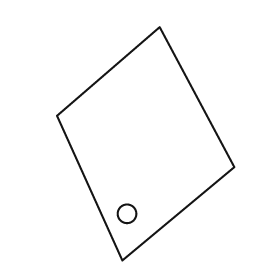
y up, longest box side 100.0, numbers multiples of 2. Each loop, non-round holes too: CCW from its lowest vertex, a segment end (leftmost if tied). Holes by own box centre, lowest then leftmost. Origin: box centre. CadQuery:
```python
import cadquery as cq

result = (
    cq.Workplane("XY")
    .moveTo(-10.0, -50.0)
    .lineTo(38.0, -10.0)
    .lineTo(6.0, 50.0)
    .lineTo(-38.0, 12.0)
    .close()
    .moveTo(-8.0, -30.0)
    .circle(4.0)
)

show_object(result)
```